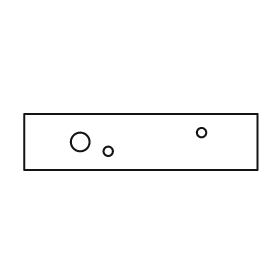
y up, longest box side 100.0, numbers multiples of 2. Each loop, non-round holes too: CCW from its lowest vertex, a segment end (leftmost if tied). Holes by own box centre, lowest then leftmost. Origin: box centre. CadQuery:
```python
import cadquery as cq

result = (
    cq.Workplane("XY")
    .moveTo(-50.0, -12.0)
    .lineTo(50.0, -12.0)
    .lineTo(50.0, 12.0)
    .lineTo(-50.0, 12.0)
    .close()
    .moveTo(-14.0, -4.0)
    .circle(2.0)
    .moveTo(-26.0, 0.0)
    .circle(4.0)
    .moveTo(26.0, 4.0)
    .circle(2.0)
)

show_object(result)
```